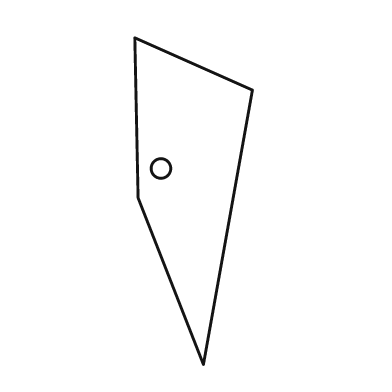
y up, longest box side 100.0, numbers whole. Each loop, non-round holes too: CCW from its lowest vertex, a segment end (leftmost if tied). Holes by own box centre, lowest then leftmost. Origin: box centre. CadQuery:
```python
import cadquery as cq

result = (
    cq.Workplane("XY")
    .moveTo(3.0, -50.0)
    .lineTo(18.0, 34.0)
    .lineTo(-18.0, 50.0)
    .lineTo(-17.0, 1.0)
    .close()
    .moveTo(-10.0, 10.0)
    .circle(3.0)
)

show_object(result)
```